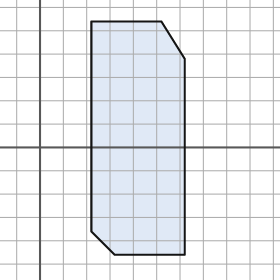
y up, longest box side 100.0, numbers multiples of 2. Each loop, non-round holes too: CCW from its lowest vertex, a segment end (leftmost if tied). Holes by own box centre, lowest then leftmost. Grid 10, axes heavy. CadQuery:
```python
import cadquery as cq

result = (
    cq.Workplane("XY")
    .moveTo(32.0, -46.0)
    .lineTo(62.0, -46.0)
    .lineTo(62.0, 38.0)
    .lineTo(52.0, 54.0)
    .lineTo(22.0, 54.0)
    .lineTo(22.0, -36.0)
    .close()
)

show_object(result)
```